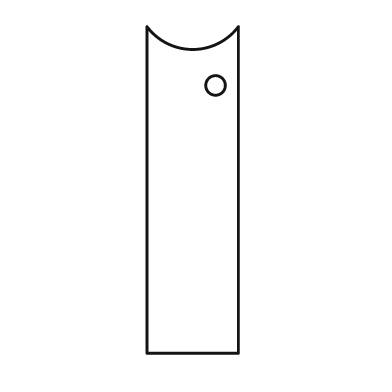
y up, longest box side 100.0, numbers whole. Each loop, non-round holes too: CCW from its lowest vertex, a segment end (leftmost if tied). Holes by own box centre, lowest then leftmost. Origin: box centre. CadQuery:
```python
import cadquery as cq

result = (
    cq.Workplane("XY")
    .moveTo(-14.0, -50.0)
    .lineTo(14.0, -50.0)
    .lineTo(14.0, 50.0)
    .threePointArc((0.0, 43.0), (-14.0, 50.0))
    .close()
    .moveTo(7.0, 32.0)
    .circle(3.0)
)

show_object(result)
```